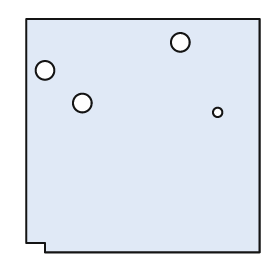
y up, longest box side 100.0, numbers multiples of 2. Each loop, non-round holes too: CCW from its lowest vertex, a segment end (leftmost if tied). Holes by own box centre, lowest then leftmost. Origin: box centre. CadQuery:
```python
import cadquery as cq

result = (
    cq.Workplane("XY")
    .moveTo(-42.0, -50.0)
    .lineTo(50.0, -50.0)
    .lineTo(50.0, 50.0)
    .lineTo(-50.0, 50.0)
    .lineTo(-50.0, -46.0)
    .lineTo(-42.0, -46.0)
    .close()
    .moveTo(32.0, 10.0)
    .circle(2.0)
    .moveTo(-26.0, 14.0)
    .circle(4.0)
    .moveTo(-42.0, 28.0)
    .circle(4.0)
    .moveTo(16.0, 40.0)
    .circle(4.0)
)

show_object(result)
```